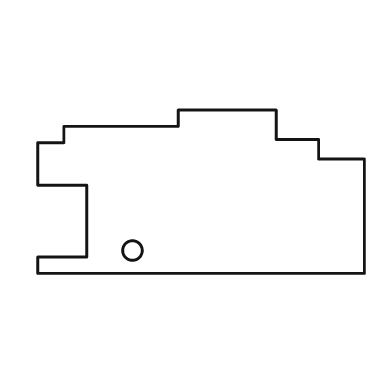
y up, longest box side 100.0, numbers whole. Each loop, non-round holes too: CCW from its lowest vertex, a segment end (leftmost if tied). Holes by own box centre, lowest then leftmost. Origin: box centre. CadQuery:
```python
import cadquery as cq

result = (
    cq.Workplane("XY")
    .moveTo(-50.0, -25.0)
    .lineTo(50.0, -25.0)
    .lineTo(50.0, 10.0)
    .lineTo(36.0, 10.0)
    .lineTo(36.0, 16.0)
    .lineTo(23.0, 16.0)
    .lineTo(23.0, 25.0)
    .lineTo(-7.0, 25.0)
    .lineTo(-7.0, 20.0)
    .lineTo(-42.0, 20.0)
    .lineTo(-42.0, 15.0)
    .lineTo(-50.0, 15.0)
    .lineTo(-50.0, 2.0)
    .lineTo(-35.0, 2.0)
    .lineTo(-35.0, -20.0)
    .lineTo(-50.0, -20.0)
    .close()
    .moveTo(-21.0, -18.0)
    .circle(3.0)
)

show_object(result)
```